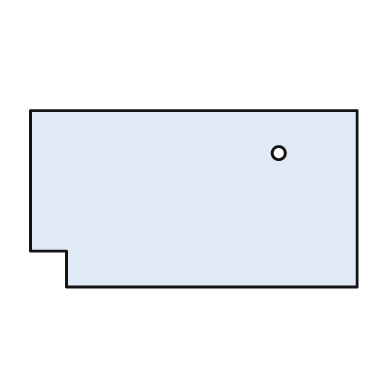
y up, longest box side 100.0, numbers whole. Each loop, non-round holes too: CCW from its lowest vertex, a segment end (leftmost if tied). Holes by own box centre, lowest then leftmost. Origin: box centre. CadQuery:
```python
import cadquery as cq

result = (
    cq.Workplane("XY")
    .moveTo(-39.0, -27.0)
    .lineTo(50.0, -27.0)
    .lineTo(50.0, 27.0)
    .lineTo(-50.0, 27.0)
    .lineTo(-50.0, -16.0)
    .lineTo(-39.0, -16.0)
    .close()
    .moveTo(26.0, 14.0)
    .circle(2.0)
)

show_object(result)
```